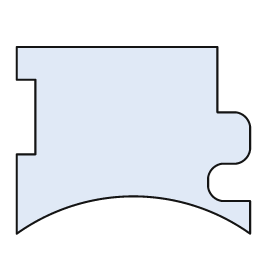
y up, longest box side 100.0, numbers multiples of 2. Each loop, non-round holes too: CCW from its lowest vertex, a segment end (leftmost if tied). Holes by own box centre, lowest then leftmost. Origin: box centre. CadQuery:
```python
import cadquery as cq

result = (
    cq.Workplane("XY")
    .moveTo(-50.0, -40.0)
    .threePointArc((0.0, -24.0), (50.0, -40.0))
    .lineTo(50.0, -26.0)
    .lineTo(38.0, -26.0)
    .threePointArc((34.0, -24.0), (32.0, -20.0))
    .lineTo(32.0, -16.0)
    .threePointArc((34.0, -12.0), (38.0, -10.0))
    .lineTo(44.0, -10.0)
    .threePointArc((48.0, -8.0), (50.0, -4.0))
    .lineTo(50.0, 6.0)
    .threePointArc((48.0, 10.0), (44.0, 12.0))
    .lineTo(36.0, 12.0)
    .lineTo(36.0, 40.0)
    .lineTo(-50.0, 40.0)
    .lineTo(-50.0, 26.0)
    .lineTo(-42.0, 26.0)
    .lineTo(-42.0, -6.0)
    .lineTo(-50.0, -6.0)
    .close()
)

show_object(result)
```